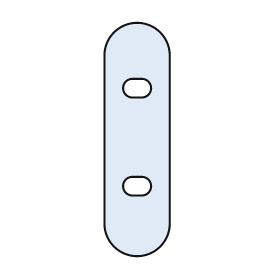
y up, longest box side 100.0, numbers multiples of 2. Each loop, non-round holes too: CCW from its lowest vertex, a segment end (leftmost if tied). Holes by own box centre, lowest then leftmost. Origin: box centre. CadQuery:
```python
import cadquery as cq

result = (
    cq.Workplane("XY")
    .moveTo(-14.0, -36.0)
    .threePointArc((0.0, -50.0), (14.0, -36.0))
    .lineTo(14.0, 36.0)
    .threePointArc((0.0, 50.0), (-14.0, 36.0))
    .close()
    .moveTo(-2.0, -24.0)
    .lineTo(2.0, -24.0)
    .threePointArc((6.0, -20.0), (2.0, -16.0))
    .lineTo(-2.0, -16.0)
    .threePointArc((-6.0, -20.0), (-2.0, -24.0))
    .close()
    .moveTo(-2.0, 18.0)
    .lineTo(2.0, 18.0)
    .threePointArc((6.0, 22.0), (2.0, 26.0))
    .lineTo(-2.0, 26.0)
    .threePointArc((-6.0, 22.0), (-2.0, 18.0))
    .close()
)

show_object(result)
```